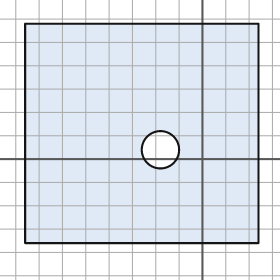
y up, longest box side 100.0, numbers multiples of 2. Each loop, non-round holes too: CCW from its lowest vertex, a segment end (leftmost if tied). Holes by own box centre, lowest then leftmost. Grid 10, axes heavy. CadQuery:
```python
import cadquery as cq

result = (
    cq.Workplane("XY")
    .moveTo(-76.0, -36.0)
    .lineTo(24.0, -36.0)
    .lineTo(24.0, 58.0)
    .lineTo(-76.0, 58.0)
    .close()
    .moveTo(-18.0, 4.0)
    .circle(8.0)
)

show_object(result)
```